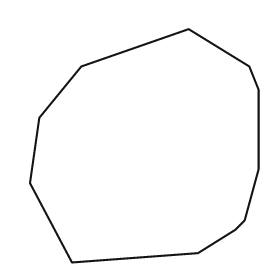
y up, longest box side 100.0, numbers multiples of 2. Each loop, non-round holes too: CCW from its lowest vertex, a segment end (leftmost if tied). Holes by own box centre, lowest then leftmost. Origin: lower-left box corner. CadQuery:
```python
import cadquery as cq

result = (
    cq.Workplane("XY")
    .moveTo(18.0, 0.0)
    .lineTo(72.0, 4.0)
    .lineTo(88.0, 14.0)
    .lineTo(92.0, 18.0)
    .lineTo(98.0, 40.0)
    .lineTo(98.0, 74.0)
    .lineTo(94.0, 84.0)
    .lineTo(68.0, 100.0)
    .lineTo(22.0, 84.0)
    .lineTo(4.0, 62.0)
    .lineTo(0.0, 34.0)
    .close()
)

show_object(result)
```